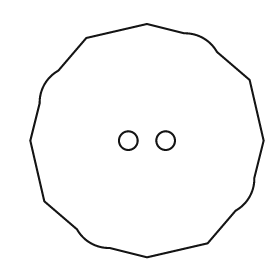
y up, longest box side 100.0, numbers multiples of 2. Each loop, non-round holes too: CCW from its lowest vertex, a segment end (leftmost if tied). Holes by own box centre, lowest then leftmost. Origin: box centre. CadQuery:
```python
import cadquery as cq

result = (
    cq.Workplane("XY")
    .moveTo(0.0, -50.0)
    .lineTo(26.0, -44.0)
    .lineTo(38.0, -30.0)
    .threePointArc((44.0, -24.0), (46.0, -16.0))
    .lineTo(50.0, 0.0)
    .lineTo(44.0, 26.0)
    .lineTo(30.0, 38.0)
    .threePointArc((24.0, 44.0), (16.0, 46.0))
    .lineTo(0.0, 50.0)
    .lineTo(-26.0, 44.0)
    .lineTo(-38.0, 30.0)
    .threePointArc((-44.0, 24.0), (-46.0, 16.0))
    .lineTo(-50.0, 0.0)
    .lineTo(-44.0, -26.0)
    .lineTo(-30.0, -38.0)
    .threePointArc((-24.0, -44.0), (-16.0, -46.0))
    .close()
    .moveTo(-8.0, 0.0)
    .circle(4.0)
    .moveTo(8.0, 0.0)
    .circle(4.0)
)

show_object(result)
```